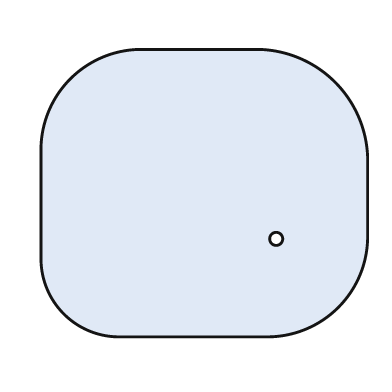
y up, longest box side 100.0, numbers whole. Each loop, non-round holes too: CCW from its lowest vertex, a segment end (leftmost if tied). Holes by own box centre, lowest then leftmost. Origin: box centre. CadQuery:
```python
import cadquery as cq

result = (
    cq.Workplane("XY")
    .moveTo(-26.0, -44.0)
    .lineTo(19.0, -44.0)
    .threePointArc((41.0, -35.0), (50.0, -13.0))
    .lineTo(50.0, 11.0)
    .threePointArc((40.0, 34.0), (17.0, 44.0))
    .lineTo(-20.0, 44.0)
    .threePointArc((-41.0, 35.0), (-50.0, 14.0))
    .lineTo(-50.0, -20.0)
    .threePointArc((-43.0, -37.0), (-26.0, -44.0))
    .close()
    .moveTo(22.0, -14.0)
    .circle(2.0)
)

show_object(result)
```